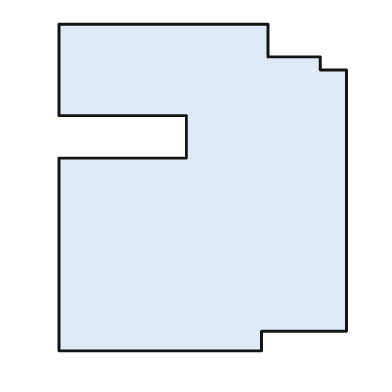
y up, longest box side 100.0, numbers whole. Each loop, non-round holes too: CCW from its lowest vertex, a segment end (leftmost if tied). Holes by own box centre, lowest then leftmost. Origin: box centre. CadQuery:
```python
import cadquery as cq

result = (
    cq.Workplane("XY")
    .moveTo(-44.0, -50.0)
    .lineTo(18.0, -50.0)
    .lineTo(18.0, -44.0)
    .lineTo(44.0, -44.0)
    .lineTo(44.0, 36.0)
    .lineTo(36.0, 36.0)
    .lineTo(36.0, 40.0)
    .lineTo(20.0, 40.0)
    .lineTo(20.0, 50.0)
    .lineTo(-44.0, 50.0)
    .lineTo(-44.0, 22.0)
    .lineTo(-5.0, 22.0)
    .lineTo(-5.0, 9.0)
    .lineTo(-44.0, 9.0)
    .close()
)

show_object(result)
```